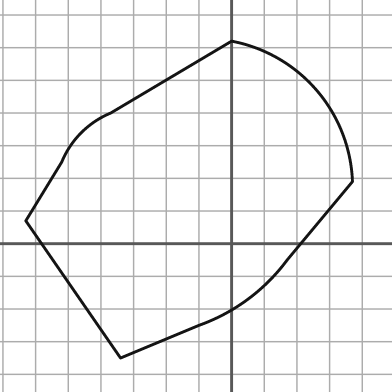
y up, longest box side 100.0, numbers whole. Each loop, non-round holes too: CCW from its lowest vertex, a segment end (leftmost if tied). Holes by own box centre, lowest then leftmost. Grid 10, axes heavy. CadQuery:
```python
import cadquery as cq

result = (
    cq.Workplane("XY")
    .moveTo(-34.0, -35.0)
    .lineTo(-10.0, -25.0)
    .threePointArc((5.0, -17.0), (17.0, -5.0))
    .lineTo(37.0, 19.0)
    .threePointArc((26.0, 47.0), (0.0, 62.0))
    .lineTo(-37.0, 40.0)
    .threePointArc((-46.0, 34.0), (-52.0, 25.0))
    .lineTo(-63.0, 7.0)
    .close()
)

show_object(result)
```